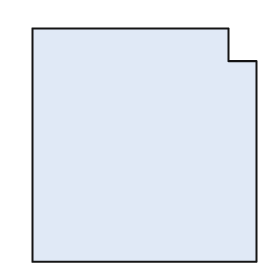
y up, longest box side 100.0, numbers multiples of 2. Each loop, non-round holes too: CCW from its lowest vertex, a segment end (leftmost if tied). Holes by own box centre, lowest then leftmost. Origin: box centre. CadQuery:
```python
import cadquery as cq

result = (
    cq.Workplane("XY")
    .moveTo(-48.0, -50.0)
    .lineTo(48.0, -50.0)
    .lineTo(48.0, 36.0)
    .lineTo(36.0, 36.0)
    .lineTo(36.0, 50.0)
    .lineTo(-48.0, 50.0)
    .close()
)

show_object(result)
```